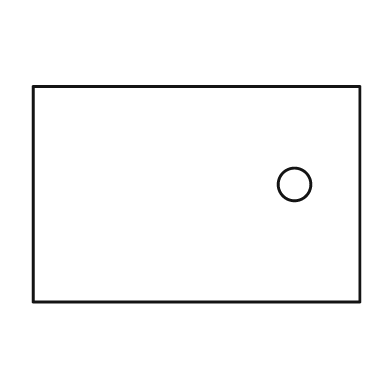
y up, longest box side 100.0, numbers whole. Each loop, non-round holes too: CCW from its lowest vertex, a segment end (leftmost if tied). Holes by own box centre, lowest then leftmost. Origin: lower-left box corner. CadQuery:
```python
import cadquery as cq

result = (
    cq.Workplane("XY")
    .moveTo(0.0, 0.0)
    .lineTo(100.0, 0.0)
    .lineTo(100.0, 66.0)
    .lineTo(0.0, 66.0)
    .close()
    .moveTo(80.0, 36.0)
    .circle(5.0)
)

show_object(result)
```